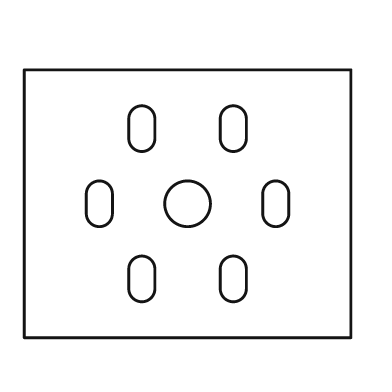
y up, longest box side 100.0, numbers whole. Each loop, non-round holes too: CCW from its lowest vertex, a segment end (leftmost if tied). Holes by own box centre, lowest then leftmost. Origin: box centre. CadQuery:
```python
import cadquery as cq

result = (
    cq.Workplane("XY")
    .moveTo(-50.0, -41.0)
    .lineTo(50.0, -41.0)
    .lineTo(50.0, 41.0)
    .lineTo(-50.0, 41.0)
    .close()
    .moveTo(-18.0, -26.0)
    .threePointArc((-14.0, -30.0), (-10.0, -26.0))
    .lineTo(-10.0, -20.0)
    .threePointArc((-14.0, -16.0), (-18.0, -20.0))
    .close()
    .moveTo(10.0, -26.0)
    .threePointArc((14.0, -30.0), (18.0, -26.0))
    .lineTo(18.0, -20.0)
    .threePointArc((14.0, -16.0), (10.0, -20.0))
    .close()
    .moveTo(-31.0, -3.0)
    .threePointArc((-27.0, -7.0), (-23.0, -3.0))
    .lineTo(-23.0, 3.0)
    .threePointArc((-27.0, 7.0), (-31.0, 3.0))
    .close()
    .moveTo(0.0, 0.0)
    .circle(7.0)
    .moveTo(23.0, -3.0)
    .threePointArc((27.0, -7.0), (31.0, -3.0))
    .lineTo(31.0, 3.0)
    .threePointArc((27.0, 7.0), (23.0, 3.0))
    .close()
    .moveTo(-18.0, 20.0)
    .threePointArc((-14.0, 16.0), (-10.0, 20.0))
    .lineTo(-10.0, 26.0)
    .threePointArc((-14.0, 30.0), (-18.0, 26.0))
    .close()
    .moveTo(10.0, 20.0)
    .threePointArc((14.0, 16.0), (18.0, 20.0))
    .lineTo(18.0, 26.0)
    .threePointArc((14.0, 30.0), (10.0, 26.0))
    .close()
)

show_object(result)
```